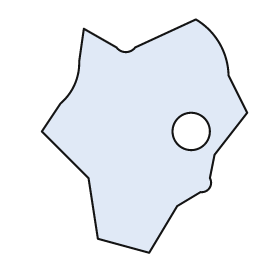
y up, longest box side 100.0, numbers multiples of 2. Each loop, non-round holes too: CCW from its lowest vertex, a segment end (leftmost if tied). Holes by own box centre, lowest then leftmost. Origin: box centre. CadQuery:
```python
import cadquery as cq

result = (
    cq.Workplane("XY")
    .moveTo(2.0, -50.0)
    .lineTo(14.0, -30.0)
    .lineTo(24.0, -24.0)
    .threePointArc((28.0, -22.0), (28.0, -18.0))
    .lineTo(30.0, -8.0)
    .lineTo(44.0, 10.0)
    .lineTo(36.0, 26.0)
    .threePointArc((32.0, 40.0), (22.0, 50.0))
    .lineTo(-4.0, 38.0)
    .threePointArc((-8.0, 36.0), (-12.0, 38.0))
    .lineTo(-26.0, 46.0)
    .lineTo(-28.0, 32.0)
    .threePointArc((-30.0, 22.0), (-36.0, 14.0))
    .lineTo(-44.0, 2.0)
    .lineTo(-24.0, -18.0)
    .lineTo(-20.0, -44.0)
    .close()
    .moveTo(20.0, 2.0)
    .circle(8.0)
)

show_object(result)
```